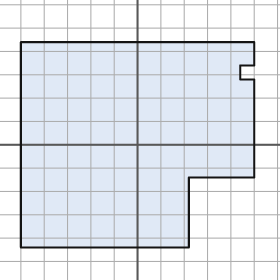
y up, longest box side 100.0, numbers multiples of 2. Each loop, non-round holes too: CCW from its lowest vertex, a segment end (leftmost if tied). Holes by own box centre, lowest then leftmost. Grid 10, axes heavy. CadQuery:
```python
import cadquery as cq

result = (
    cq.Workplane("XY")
    .moveTo(-50.0, -44.0)
    .lineTo(22.0, -44.0)
    .lineTo(22.0, -14.0)
    .lineTo(50.0, -14.0)
    .lineTo(50.0, 28.0)
    .lineTo(44.0, 28.0)
    .lineTo(44.0, 34.0)
    .lineTo(50.0, 34.0)
    .lineTo(50.0, 44.0)
    .lineTo(-50.0, 44.0)
    .close()
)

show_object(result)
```